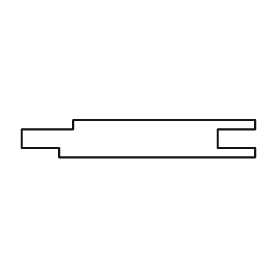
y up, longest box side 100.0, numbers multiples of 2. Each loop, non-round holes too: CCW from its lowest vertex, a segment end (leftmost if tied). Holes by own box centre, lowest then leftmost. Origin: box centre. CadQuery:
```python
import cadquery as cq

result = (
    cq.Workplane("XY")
    .moveTo(-34.0, -8.0)
    .lineTo(50.0, -8.0)
    .lineTo(50.0, -4.0)
    .lineTo(34.0, -4.0)
    .lineTo(34.0, 4.0)
    .lineTo(50.0, 4.0)
    .lineTo(50.0, 8.0)
    .lineTo(-28.0, 8.0)
    .lineTo(-28.0, 4.0)
    .lineTo(-50.0, 4.0)
    .lineTo(-50.0, -4.0)
    .lineTo(-34.0, -4.0)
    .close()
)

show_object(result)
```